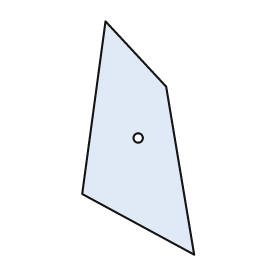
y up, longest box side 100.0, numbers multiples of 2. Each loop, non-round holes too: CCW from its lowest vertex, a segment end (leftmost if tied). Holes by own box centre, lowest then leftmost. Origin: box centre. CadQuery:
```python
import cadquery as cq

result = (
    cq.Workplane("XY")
    .moveTo(24.0, -50.0)
    .lineTo(12.0, 22.0)
    .lineTo(-14.0, 50.0)
    .lineTo(-24.0, -24.0)
    .close()
    .moveTo(0.0, 0.0)
    .circle(2.0)
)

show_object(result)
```